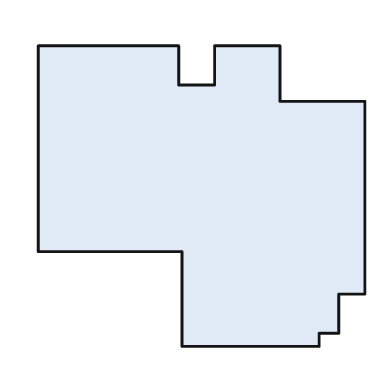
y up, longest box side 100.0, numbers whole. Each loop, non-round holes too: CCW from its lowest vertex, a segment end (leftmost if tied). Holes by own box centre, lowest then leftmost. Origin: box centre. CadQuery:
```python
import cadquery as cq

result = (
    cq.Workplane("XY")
    .moveTo(-6.0, -46.0)
    .lineTo(36.0, -46.0)
    .lineTo(36.0, -42.0)
    .lineTo(42.0, -42.0)
    .lineTo(42.0, -30.0)
    .lineTo(50.0, -30.0)
    .lineTo(50.0, 29.0)
    .lineTo(24.0, 29.0)
    .lineTo(24.0, 46.0)
    .lineTo(4.0, 46.0)
    .lineTo(4.0, 34.0)
    .lineTo(-7.0, 34.0)
    .lineTo(-7.0, 46.0)
    .lineTo(-50.0, 46.0)
    .lineTo(-50.0, -17.0)
    .lineTo(-6.0, -17.0)
    .close()
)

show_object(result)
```